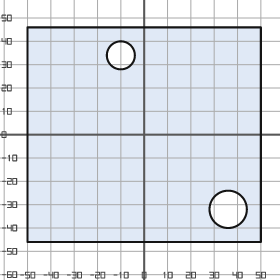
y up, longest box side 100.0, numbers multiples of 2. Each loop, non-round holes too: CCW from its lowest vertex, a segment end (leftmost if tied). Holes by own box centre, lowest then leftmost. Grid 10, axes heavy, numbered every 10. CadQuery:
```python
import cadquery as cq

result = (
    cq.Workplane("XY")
    .moveTo(-50.0, -46.0)
    .lineTo(50.0, -46.0)
    .lineTo(50.0, 46.0)
    .lineTo(-50.0, 46.0)
    .close()
    .moveTo(36.0, -32.0)
    .circle(8.0)
    .moveTo(-10.0, 34.0)
    .circle(6.0)
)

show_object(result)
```